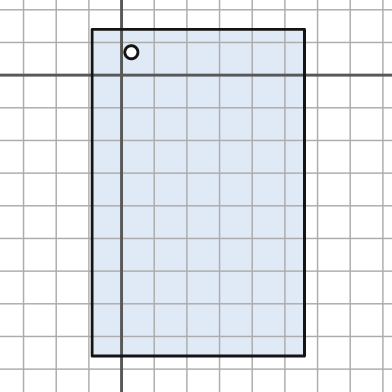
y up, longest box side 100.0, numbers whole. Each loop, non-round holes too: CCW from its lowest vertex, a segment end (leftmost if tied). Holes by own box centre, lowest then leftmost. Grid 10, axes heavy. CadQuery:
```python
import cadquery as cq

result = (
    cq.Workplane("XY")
    .moveTo(-9.0, -86.0)
    .lineTo(56.0, -86.0)
    .lineTo(56.0, 14.0)
    .lineTo(-9.0, 14.0)
    .close()
    .moveTo(3.0, 7.0)
    .circle(2.0)
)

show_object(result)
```